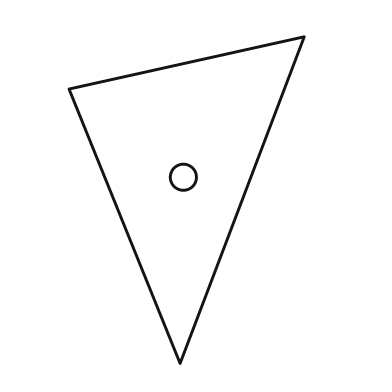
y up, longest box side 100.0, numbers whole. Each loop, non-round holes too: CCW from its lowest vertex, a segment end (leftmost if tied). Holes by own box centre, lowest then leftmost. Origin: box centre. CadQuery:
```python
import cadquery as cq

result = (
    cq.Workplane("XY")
    .moveTo(-2.0, -50.0)
    .lineTo(36.0, 50.0)
    .lineTo(-36.0, 34.0)
    .close()
    .moveTo(-1.0, 7.0)
    .circle(4.0)
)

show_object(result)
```